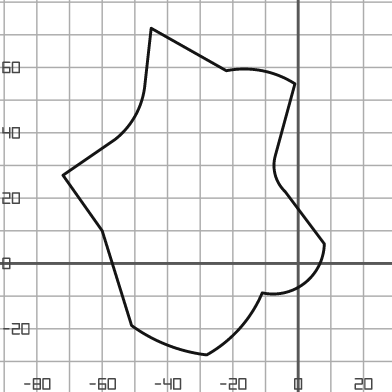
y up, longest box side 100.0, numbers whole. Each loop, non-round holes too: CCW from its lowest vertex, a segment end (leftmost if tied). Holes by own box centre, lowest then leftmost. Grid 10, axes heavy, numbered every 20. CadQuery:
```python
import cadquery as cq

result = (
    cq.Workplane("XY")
    .moveTo(-28.0, -28.0)
    .threePointArc((-18.0, -20.0), (-11.0, -9.0))
    .threePointArc((2.0, -6.0), (8.0, 6.0))
    .lineTo(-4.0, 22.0)
    .threePointArc((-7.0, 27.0), (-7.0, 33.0))
    .lineTo(-1.0, 55.0)
    .threePointArc((-11.0, 59.0), (-22.0, 59.0))
    .lineTo(-45.0, 72.0)
    .lineTo(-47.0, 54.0)
    .threePointArc((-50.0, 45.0), (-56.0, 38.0))
    .lineTo(-72.0, 27.0)
    .lineTo(-60.0, 10.0)
    .lineTo(-51.0, -19.0)
    .threePointArc((-40.0, -25.0), (-28.0, -28.0))
    .close()
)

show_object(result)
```